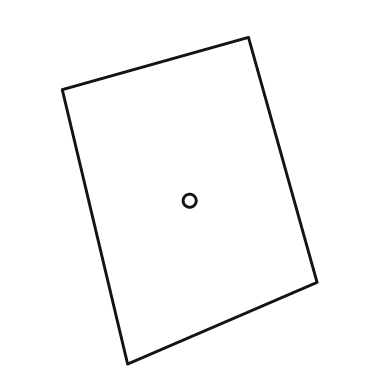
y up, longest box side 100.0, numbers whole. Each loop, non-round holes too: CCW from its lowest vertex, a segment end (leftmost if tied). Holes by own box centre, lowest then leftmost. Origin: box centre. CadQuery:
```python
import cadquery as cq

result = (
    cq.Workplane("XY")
    .moveTo(-19.0, -50.0)
    .lineTo(39.0, -25.0)
    .lineTo(18.0, 50.0)
    .lineTo(-39.0, 34.0)
    .close()
    .moveTo(0.0, 0.0)
    .circle(2.0)
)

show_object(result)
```